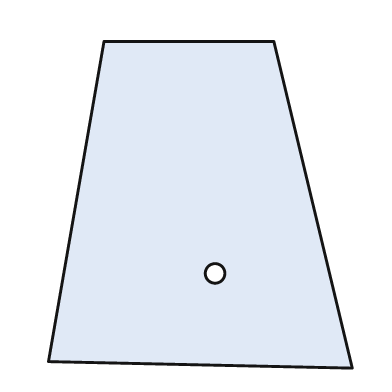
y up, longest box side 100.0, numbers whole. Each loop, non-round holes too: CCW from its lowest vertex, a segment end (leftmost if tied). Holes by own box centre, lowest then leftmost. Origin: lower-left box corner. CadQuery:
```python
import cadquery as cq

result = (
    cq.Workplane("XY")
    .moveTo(93.0, 0.0)
    .lineTo(69.0, 100.0)
    .lineTo(17.0, 100.0)
    .lineTo(0.0, 2.0)
    .close()
    .moveTo(51.0, 29.0)
    .circle(3.0)
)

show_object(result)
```